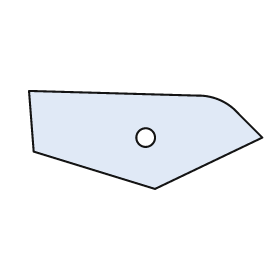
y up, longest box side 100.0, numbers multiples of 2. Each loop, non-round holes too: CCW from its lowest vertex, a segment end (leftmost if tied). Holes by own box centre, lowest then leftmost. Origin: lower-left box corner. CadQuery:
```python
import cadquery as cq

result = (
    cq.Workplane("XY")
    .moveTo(54.0, 0.0)
    .lineTo(100.0, 22.0)
    .lineTo(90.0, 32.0)
    .threePointArc((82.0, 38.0), (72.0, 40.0))
    .lineTo(0.0, 42.0)
    .lineTo(2.0, 16.0)
    .close()
    .moveTo(50.0, 22.0)
    .circle(4.0)
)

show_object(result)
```